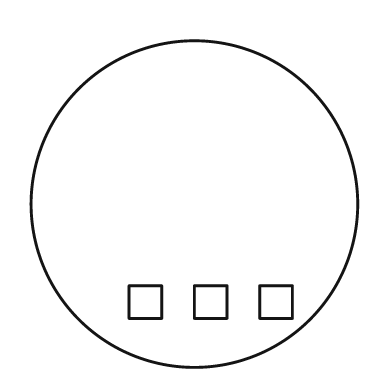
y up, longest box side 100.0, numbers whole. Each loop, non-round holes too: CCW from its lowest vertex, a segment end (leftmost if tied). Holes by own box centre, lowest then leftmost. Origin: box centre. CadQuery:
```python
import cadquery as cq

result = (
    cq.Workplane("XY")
    .moveTo(0.0, 0.0)
    .circle(50.0)
    .moveTo(-20.0, -35.0)
    .lineTo(-10.0, -35.0)
    .lineTo(-10.0, -25.0)
    .lineTo(-20.0, -25.0)
    .close()
    .moveTo(0.0, -35.0)
    .lineTo(10.0, -35.0)
    .lineTo(10.0, -25.0)
    .lineTo(0.0, -25.0)
    .close()
    .moveTo(20.0, -35.0)
    .lineTo(30.0, -35.0)
    .lineTo(30.0, -25.0)
    .lineTo(20.0, -25.0)
    .close()
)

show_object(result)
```